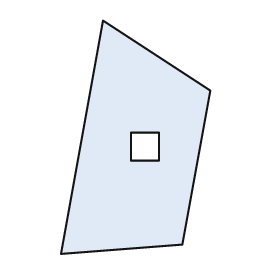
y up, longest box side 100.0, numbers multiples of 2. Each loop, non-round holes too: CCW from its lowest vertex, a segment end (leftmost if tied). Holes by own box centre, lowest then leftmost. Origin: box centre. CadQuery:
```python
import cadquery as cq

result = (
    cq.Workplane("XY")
    .moveTo(-32.0, -50.0)
    .lineTo(20.0, -46.0)
    .lineTo(32.0, 20.0)
    .lineTo(-14.0, 50.0)
    .close()
    .moveTo(-2.0, -10.0)
    .lineTo(10.0, -10.0)
    .lineTo(10.0, 2.0)
    .lineTo(-2.0, 2.0)
    .close()
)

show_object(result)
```